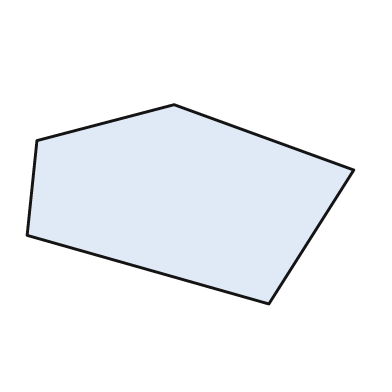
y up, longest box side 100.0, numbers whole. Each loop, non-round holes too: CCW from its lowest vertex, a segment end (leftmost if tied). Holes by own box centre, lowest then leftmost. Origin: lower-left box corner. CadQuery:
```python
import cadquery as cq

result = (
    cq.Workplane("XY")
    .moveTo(74.0, 0.0)
    .lineTo(100.0, 41.0)
    .lineTo(45.0, 61.0)
    .lineTo(3.0, 50.0)
    .lineTo(0.0, 21.0)
    .close()
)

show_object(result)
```